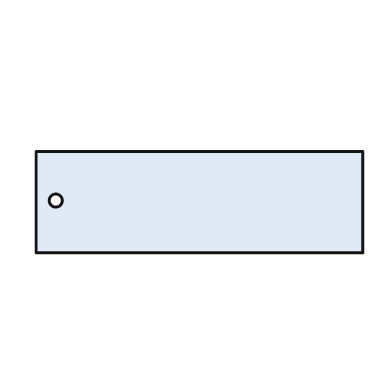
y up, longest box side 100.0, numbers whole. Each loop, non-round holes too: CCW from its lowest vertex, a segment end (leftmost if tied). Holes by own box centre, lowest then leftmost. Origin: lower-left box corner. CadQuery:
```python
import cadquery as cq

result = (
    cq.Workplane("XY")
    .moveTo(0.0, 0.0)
    .lineTo(100.0, 0.0)
    .lineTo(100.0, 31.0)
    .lineTo(0.0, 31.0)
    .close()
    .moveTo(6.0, 16.0)
    .circle(2.0)
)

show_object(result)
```